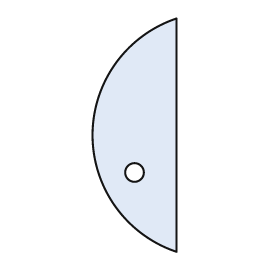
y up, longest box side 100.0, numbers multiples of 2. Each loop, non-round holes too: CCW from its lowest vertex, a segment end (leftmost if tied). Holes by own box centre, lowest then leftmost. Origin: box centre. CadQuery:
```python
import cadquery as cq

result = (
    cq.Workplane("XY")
    .moveTo(18.0, -50.0)
    .lineTo(18.0, 50.0)
    .threePointArc((-18.0, 0.0), (18.0, -50.0))
    .close()
    .moveTo(0.0, -16.0)
    .circle(4.0)
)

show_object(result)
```